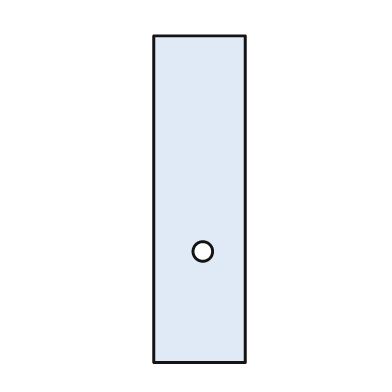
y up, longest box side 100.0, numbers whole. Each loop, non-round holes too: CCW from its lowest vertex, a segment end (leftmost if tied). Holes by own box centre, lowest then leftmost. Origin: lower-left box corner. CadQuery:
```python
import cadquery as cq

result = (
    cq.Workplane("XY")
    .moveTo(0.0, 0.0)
    .lineTo(28.0, 0.0)
    .lineTo(28.0, 100.0)
    .lineTo(0.0, 100.0)
    .close()
    .moveTo(15.0, 34.0)
    .circle(3.0)
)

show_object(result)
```